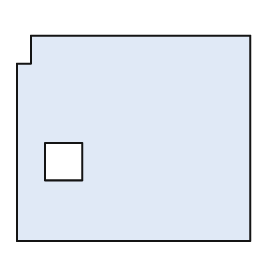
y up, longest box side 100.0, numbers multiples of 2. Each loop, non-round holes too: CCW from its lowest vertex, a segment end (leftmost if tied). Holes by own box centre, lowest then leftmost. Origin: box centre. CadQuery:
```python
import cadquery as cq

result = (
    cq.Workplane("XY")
    .moveTo(-50.0, -44.0)
    .lineTo(50.0, -44.0)
    .lineTo(50.0, 44.0)
    .lineTo(-44.0, 44.0)
    .lineTo(-44.0, 32.0)
    .lineTo(-50.0, 32.0)
    .close()
    .moveTo(-38.0, -18.0)
    .lineTo(-22.0, -18.0)
    .lineTo(-22.0, -2.0)
    .lineTo(-38.0, -2.0)
    .close()
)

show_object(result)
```